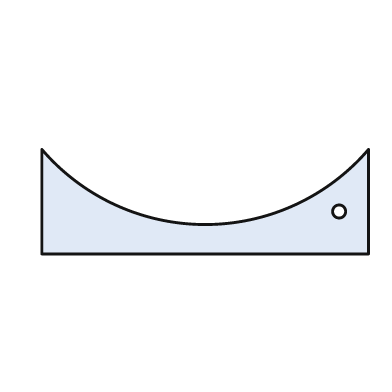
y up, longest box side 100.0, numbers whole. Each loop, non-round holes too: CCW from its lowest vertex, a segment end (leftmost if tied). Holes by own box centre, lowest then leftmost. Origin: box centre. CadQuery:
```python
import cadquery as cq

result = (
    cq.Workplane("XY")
    .moveTo(-50.0, -16.0)
    .lineTo(50.0, -16.0)
    .lineTo(50.0, 16.0)
    .threePointArc((0.0, -7.0), (-50.0, 16.0))
    .close()
    .moveTo(41.0, -3.0)
    .circle(2.0)
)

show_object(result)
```